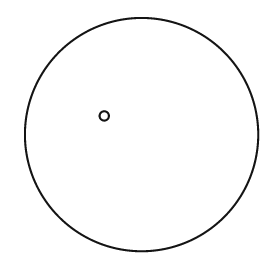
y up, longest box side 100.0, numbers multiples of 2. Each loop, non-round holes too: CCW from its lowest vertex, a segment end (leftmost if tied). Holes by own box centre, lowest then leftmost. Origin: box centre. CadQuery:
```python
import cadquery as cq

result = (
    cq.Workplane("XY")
    .moveTo(0.0, 0.0)
    .circle(50.0)
    .moveTo(-16.0, 8.0)
    .circle(2.0)
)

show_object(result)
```